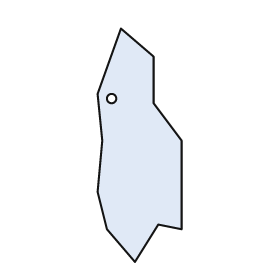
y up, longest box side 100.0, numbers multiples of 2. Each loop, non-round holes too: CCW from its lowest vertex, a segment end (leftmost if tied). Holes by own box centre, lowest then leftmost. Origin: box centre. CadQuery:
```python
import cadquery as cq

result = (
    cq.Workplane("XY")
    .moveTo(-2.0, -50.0)
    .lineTo(8.0, -34.0)
    .lineTo(18.0, -36.0)
    .lineTo(18.0, 2.0)
    .lineTo(6.0, 18.0)
    .lineTo(6.0, 38.0)
    .lineTo(-8.0, 50.0)
    .lineTo(-18.0, 22.0)
    .lineTo(-16.0, 2.0)
    .lineTo(-18.0, -20.0)
    .lineTo(-14.0, -36.0)
    .close()
    .moveTo(-12.0, 20.0)
    .circle(2.0)
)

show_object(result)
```